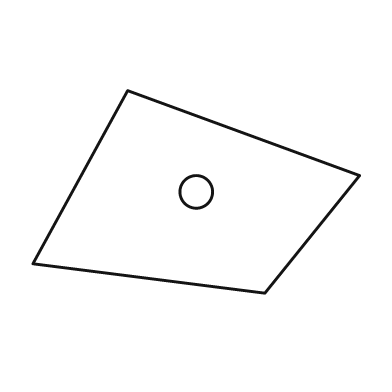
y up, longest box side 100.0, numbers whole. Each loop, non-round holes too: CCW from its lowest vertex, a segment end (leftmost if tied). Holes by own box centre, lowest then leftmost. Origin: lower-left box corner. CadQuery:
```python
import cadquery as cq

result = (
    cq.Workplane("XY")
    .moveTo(71.0, 0.0)
    .lineTo(100.0, 36.0)
    .lineTo(29.0, 62.0)
    .lineTo(0.0, 9.0)
    .close()
    .moveTo(50.0, 31.0)
    .circle(5.0)
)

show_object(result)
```